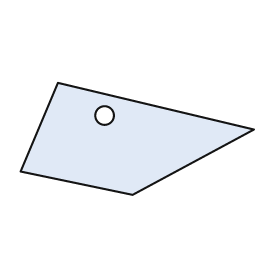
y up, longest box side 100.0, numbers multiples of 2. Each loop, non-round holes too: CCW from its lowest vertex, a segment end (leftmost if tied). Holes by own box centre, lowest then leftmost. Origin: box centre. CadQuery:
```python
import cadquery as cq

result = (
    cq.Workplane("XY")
    .moveTo(-2.0, -24.0)
    .lineTo(50.0, 4.0)
    .lineTo(-34.0, 24.0)
    .lineTo(-50.0, -14.0)
    .close()
    .moveTo(-14.0, 10.0)
    .circle(4.0)
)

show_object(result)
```